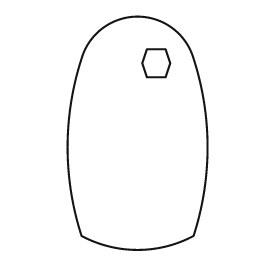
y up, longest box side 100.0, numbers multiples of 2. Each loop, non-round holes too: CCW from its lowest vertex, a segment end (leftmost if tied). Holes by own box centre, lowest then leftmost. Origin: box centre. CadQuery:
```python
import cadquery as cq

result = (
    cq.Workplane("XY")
    .moveTo(-24.0, -44.0)
    .threePointArc((0.0, -50.0), (24.0, -44.0))
    .threePointArc((30.0, -6.0), (24.0, 32.0))
    .threePointArc((0.0, 50.0), (-24.0, 32.0))
    .threePointArc((-30.0, -6.0), (-24.0, -44.0))
    .close()
    .moveTo(4.0, 24.0)
    .lineTo(12.0, 24.0)
    .lineTo(14.0, 30.0)
    .lineTo(12.0, 36.0)
    .lineTo(4.0, 36.0)
    .lineTo(2.0, 30.0)
    .close()
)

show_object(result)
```